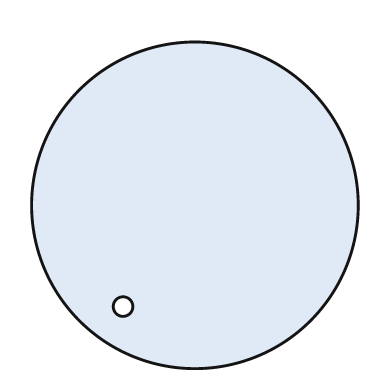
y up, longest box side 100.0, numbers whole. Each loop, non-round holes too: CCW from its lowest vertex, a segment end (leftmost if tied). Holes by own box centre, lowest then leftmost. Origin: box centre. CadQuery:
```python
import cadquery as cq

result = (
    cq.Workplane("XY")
    .moveTo(0.0, 0.0)
    .circle(50.0)
    .moveTo(-22.0, -31.0)
    .circle(3.0)
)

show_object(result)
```